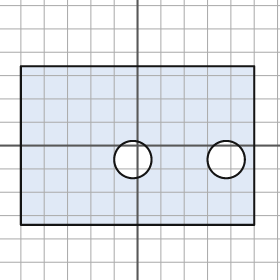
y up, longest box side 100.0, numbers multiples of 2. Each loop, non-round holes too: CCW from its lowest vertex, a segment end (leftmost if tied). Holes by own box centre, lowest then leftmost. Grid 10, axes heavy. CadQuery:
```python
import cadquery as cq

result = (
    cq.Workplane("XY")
    .moveTo(-50.0, -34.0)
    .lineTo(50.0, -34.0)
    .lineTo(50.0, 34.0)
    .lineTo(-50.0, 34.0)
    .close()
    .moveTo(-2.0, -6.0)
    .circle(8.0)
    .moveTo(38.0, -6.0)
    .circle(8.0)
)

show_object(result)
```